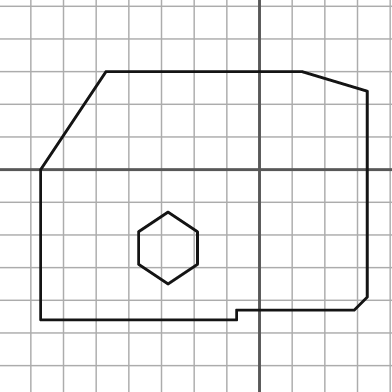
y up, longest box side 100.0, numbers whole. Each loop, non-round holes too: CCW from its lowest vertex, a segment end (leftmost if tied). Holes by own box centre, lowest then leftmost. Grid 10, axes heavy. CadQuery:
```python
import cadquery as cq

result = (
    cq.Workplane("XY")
    .moveTo(-67.0, -46.0)
    .lineTo(-7.0, -46.0)
    .lineTo(-7.0, -43.0)
    .lineTo(29.0, -43.0)
    .lineTo(33.0, -39.0)
    .lineTo(33.0, 24.0)
    .lineTo(13.0, 30.0)
    .lineTo(-47.0, 30.0)
    .lineTo(-67.0, 0.0)
    .close()
    .moveTo(-28.0, -35.0)
    .lineTo(-19.0, -29.0)
    .lineTo(-19.0, -19.0)
    .lineTo(-28.0, -13.0)
    .lineTo(-37.0, -19.0)
    .lineTo(-37.0, -29.0)
    .close()
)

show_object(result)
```